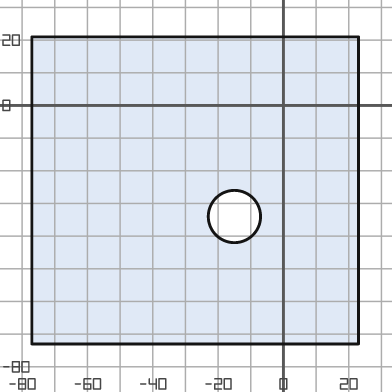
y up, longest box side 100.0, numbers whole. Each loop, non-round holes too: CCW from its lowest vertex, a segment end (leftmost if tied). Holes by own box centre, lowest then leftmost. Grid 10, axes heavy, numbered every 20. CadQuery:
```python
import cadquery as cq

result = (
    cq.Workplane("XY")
    .moveTo(-77.0, -73.0)
    .lineTo(23.0, -73.0)
    .lineTo(23.0, 21.0)
    .lineTo(-77.0, 21.0)
    .close()
    .moveTo(-15.0, -34.0)
    .circle(8.0)
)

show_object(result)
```